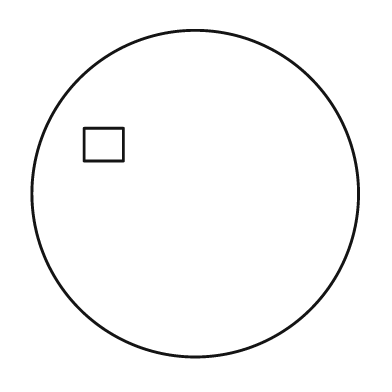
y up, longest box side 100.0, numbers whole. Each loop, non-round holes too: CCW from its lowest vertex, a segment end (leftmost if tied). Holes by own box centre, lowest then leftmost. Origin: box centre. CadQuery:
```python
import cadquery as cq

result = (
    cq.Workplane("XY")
    .moveTo(0.0, 0.0)
    .circle(50.0)
    .moveTo(-34.0, 10.0)
    .lineTo(-22.0, 10.0)
    .lineTo(-22.0, 20.0)
    .lineTo(-34.0, 20.0)
    .close()
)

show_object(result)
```